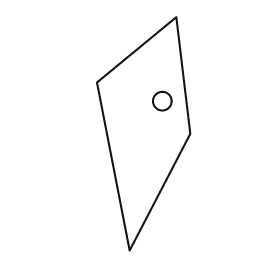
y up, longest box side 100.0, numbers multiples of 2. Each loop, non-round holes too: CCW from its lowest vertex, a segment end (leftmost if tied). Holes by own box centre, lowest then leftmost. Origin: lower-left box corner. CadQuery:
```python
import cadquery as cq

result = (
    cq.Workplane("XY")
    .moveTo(14.0, 0.0)
    .lineTo(40.0, 50.0)
    .lineTo(34.0, 100.0)
    .lineTo(0.0, 72.0)
    .close()
    .moveTo(28.0, 64.0)
    .circle(4.0)
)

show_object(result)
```